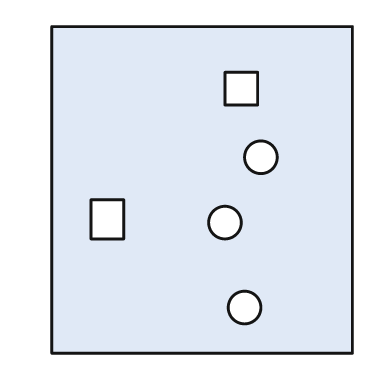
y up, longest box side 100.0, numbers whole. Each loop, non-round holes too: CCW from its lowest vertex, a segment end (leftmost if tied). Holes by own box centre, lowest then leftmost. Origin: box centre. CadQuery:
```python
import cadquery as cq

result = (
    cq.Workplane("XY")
    .moveTo(-46.0, -50.0)
    .lineTo(46.0, -50.0)
    .lineTo(46.0, 50.0)
    .lineTo(-46.0, 50.0)
    .close()
    .moveTo(13.0, -36.0)
    .circle(5.0)
    .moveTo(7.0, -10.0)
    .circle(5.0)
    .moveTo(-34.0, -15.0)
    .lineTo(-24.0, -15.0)
    .lineTo(-24.0, -3.0)
    .lineTo(-34.0, -3.0)
    .close()
    .moveTo(18.0, 10.0)
    .circle(5.0)
    .moveTo(7.0, 26.0)
    .lineTo(17.0, 26.0)
    .lineTo(17.0, 36.0)
    .lineTo(7.0, 36.0)
    .close()
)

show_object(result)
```